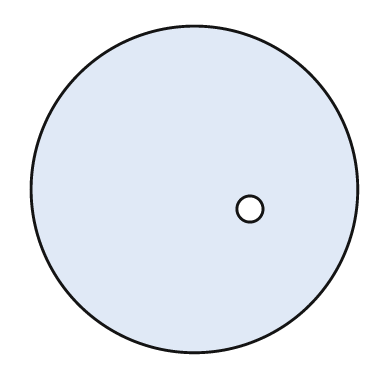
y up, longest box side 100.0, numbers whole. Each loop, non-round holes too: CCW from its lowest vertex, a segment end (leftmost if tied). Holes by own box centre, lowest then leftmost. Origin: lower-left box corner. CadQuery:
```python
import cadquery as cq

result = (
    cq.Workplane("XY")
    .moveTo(50.0, 50.0)
    .circle(50.0)
    .moveTo(67.0, 44.0)
    .circle(4.0)
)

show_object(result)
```